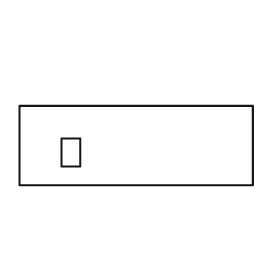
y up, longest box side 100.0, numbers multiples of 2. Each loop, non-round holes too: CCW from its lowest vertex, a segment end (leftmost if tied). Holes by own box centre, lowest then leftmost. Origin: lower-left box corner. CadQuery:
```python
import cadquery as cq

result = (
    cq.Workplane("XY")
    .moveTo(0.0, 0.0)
    .lineTo(100.0, 0.0)
    .lineTo(100.0, 34.0)
    .lineTo(0.0, 34.0)
    .close()
    .moveTo(18.0, 8.0)
    .lineTo(26.0, 8.0)
    .lineTo(26.0, 20.0)
    .lineTo(18.0, 20.0)
    .close()
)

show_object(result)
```